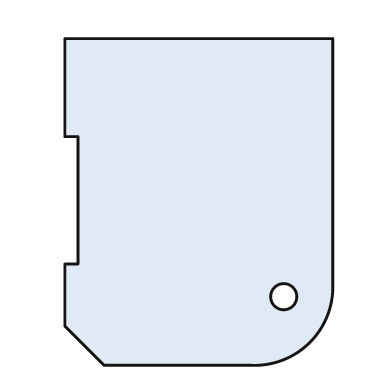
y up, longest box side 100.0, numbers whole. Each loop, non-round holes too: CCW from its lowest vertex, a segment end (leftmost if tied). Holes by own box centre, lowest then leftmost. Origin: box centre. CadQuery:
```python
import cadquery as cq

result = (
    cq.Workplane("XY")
    .moveTo(-29.0, -50.0)
    .lineTo(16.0, -50.0)
    .threePointArc((34.0, -43.0), (41.0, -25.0))
    .lineTo(41.0, 50.0)
    .lineTo(-41.0, 50.0)
    .lineTo(-41.0, 20.0)
    .lineTo(-37.0, 20.0)
    .lineTo(-37.0, -19.0)
    .lineTo(-41.0, -19.0)
    .lineTo(-41.0, -38.0)
    .close()
    .moveTo(26.0, -29.0)
    .circle(4.0)
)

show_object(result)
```